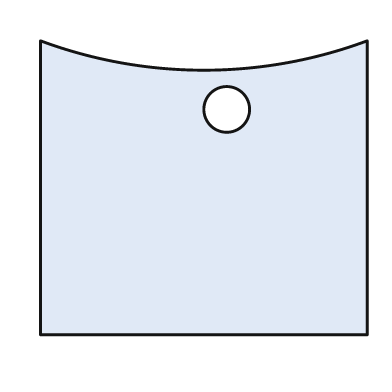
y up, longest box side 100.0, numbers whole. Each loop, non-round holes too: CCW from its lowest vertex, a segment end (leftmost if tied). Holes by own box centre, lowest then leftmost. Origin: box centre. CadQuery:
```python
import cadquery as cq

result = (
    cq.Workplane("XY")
    .moveTo(-50.0, -45.0)
    .lineTo(50.0, -45.0)
    .lineTo(50.0, 45.0)
    .threePointArc((0.0, 36.0), (-50.0, 45.0))
    .close()
    .moveTo(7.0, 24.0)
    .circle(7.0)
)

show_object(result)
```